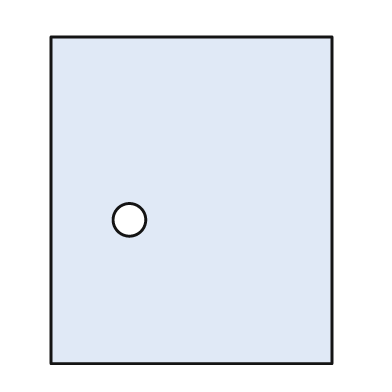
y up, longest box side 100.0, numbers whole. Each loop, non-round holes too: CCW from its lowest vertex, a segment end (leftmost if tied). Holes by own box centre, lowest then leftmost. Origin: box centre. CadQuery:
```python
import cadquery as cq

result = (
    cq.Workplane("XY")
    .moveTo(-43.0, -50.0)
    .lineTo(43.0, -50.0)
    .lineTo(43.0, 50.0)
    .lineTo(-43.0, 50.0)
    .close()
    .moveTo(-19.0, -6.0)
    .circle(5.0)
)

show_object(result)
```